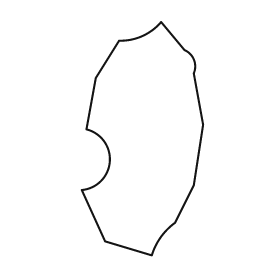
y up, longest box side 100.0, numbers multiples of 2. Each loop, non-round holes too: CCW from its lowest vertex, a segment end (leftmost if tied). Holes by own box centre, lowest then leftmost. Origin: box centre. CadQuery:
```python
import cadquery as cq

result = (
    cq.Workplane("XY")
    .moveTo(4.0, -50.0)
    .threePointArc((8.0, -42.0), (14.0, -36.0))
    .lineTo(22.0, -20.0)
    .lineTo(26.0, 6.0)
    .lineTo(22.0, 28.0)
    .threePointArc((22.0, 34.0), (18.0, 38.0))
    .lineTo(8.0, 50.0)
    .threePointArc((0.0, 44.0), (-10.0, 42.0))
    .lineTo(-20.0, 26.0)
    .lineTo(-24.0, 4.0)
    .threePointArc((-14.0, -10.0), (-26.0, -22.0))
    .lineTo(-16.0, -44.0)
    .close()
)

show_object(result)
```